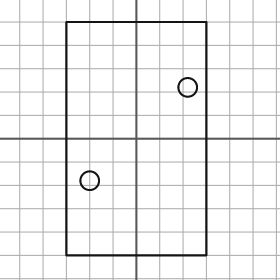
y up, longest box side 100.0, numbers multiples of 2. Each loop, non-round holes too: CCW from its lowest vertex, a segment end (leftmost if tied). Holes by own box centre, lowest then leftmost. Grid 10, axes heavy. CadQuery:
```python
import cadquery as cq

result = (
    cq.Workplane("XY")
    .moveTo(-30.0, -50.0)
    .lineTo(30.0, -50.0)
    .lineTo(30.0, 50.0)
    .lineTo(-30.0, 50.0)
    .close()
    .moveTo(-20.0, -18.0)
    .circle(4.0)
    .moveTo(22.0, 22.0)
    .circle(4.0)
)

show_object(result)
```